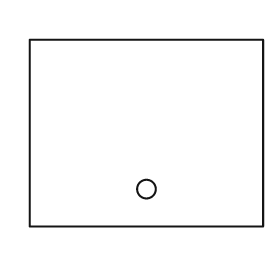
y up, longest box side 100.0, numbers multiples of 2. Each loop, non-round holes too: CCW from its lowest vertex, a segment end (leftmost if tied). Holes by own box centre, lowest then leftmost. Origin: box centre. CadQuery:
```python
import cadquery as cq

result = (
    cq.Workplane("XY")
    .moveTo(-50.0, -40.0)
    .lineTo(50.0, -40.0)
    .lineTo(50.0, 40.0)
    .lineTo(-50.0, 40.0)
    .close()
    .moveTo(0.0, -24.0)
    .circle(4.0)
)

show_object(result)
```